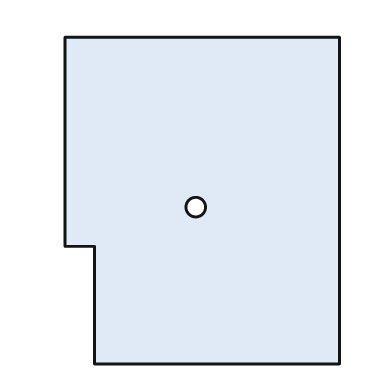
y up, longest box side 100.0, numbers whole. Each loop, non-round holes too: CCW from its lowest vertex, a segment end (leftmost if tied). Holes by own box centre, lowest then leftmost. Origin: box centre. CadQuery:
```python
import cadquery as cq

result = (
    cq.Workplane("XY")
    .moveTo(-33.0, -50.0)
    .lineTo(42.0, -50.0)
    .lineTo(42.0, 50.0)
    .lineTo(-42.0, 50.0)
    .lineTo(-42.0, -14.0)
    .lineTo(-33.0, -14.0)
    .close()
    .moveTo(-2.0, -2.0)
    .circle(3.0)
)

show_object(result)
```